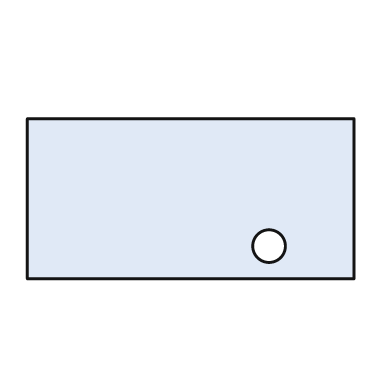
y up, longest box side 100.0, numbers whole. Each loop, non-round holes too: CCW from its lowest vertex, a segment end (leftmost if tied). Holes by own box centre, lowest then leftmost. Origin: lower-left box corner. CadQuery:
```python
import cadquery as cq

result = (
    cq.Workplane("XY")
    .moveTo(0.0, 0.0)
    .lineTo(100.0, 0.0)
    .lineTo(100.0, 49.0)
    .lineTo(0.0, 49.0)
    .close()
    .moveTo(74.0, 10.0)
    .circle(5.0)
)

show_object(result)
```